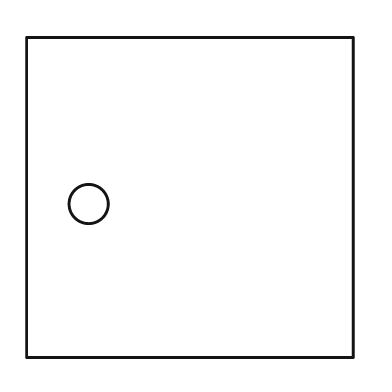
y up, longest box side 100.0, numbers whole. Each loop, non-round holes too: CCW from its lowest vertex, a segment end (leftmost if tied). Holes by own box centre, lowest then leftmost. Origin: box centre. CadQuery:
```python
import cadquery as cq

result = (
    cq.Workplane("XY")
    .moveTo(-50.0, -49.0)
    .lineTo(50.0, -49.0)
    .lineTo(50.0, 49.0)
    .lineTo(-50.0, 49.0)
    .close()
    .moveTo(-31.0, -2.0)
    .circle(6.0)
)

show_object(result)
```